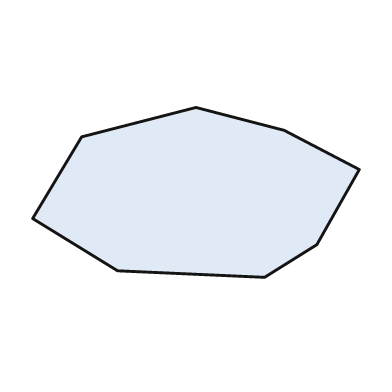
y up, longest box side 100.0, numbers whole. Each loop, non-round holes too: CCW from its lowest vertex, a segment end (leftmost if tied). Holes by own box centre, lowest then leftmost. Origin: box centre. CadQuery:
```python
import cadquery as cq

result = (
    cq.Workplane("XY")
    .moveTo(21.0, -26.0)
    .lineTo(37.0, -16.0)
    .lineTo(50.0, 7.0)
    .lineTo(27.0, 19.0)
    .lineTo(0.0, 26.0)
    .lineTo(-35.0, 17.0)
    .lineTo(-50.0, -8.0)
    .lineTo(-24.0, -24.0)
    .close()
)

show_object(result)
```